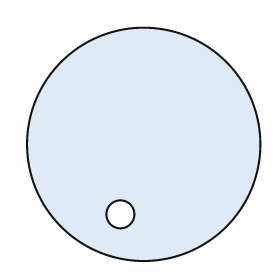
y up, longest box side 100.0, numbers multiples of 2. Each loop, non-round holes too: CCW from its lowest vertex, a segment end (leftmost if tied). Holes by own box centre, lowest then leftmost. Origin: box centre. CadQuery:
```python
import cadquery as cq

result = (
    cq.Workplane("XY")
    .moveTo(0.0, 0.0)
    .circle(50.0)
    .moveTo(-10.0, -30.0)
    .circle(6.0)
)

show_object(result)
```